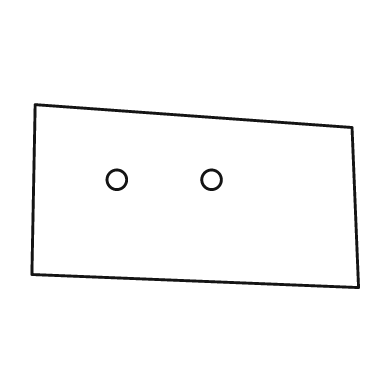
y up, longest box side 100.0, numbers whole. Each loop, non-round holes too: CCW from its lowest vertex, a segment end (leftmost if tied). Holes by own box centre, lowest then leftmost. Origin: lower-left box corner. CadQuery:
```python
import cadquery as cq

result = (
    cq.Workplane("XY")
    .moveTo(100.0, 0.0)
    .lineTo(98.0, 49.0)
    .lineTo(1.0, 56.0)
    .lineTo(0.0, 4.0)
    .close()
    .moveTo(26.0, 33.0)
    .circle(3.0)
    .moveTo(55.0, 33.0)
    .circle(3.0)
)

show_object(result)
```